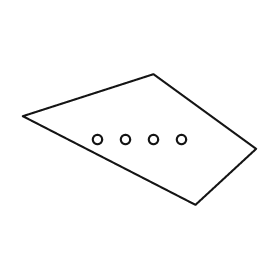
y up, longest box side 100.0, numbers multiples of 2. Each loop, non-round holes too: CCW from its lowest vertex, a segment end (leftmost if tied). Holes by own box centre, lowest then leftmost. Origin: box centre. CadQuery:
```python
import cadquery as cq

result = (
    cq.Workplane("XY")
    .moveTo(24.0, -28.0)
    .lineTo(50.0, -4.0)
    .lineTo(6.0, 28.0)
    .lineTo(-50.0, 10.0)
    .close()
    .moveTo(-18.0, 0.0)
    .circle(2.0)
    .moveTo(-6.0, 0.0)
    .circle(2.0)
    .moveTo(6.0, 0.0)
    .circle(2.0)
    .moveTo(18.0, 0.0)
    .circle(2.0)
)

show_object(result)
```